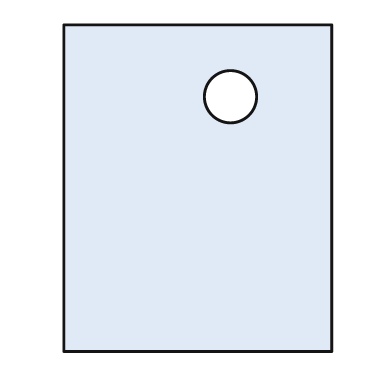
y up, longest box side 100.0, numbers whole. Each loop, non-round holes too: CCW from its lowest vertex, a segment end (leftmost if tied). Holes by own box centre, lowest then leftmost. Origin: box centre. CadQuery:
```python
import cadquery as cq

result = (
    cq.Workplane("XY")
    .moveTo(-41.0, -50.0)
    .lineTo(41.0, -50.0)
    .lineTo(41.0, 50.0)
    .lineTo(-41.0, 50.0)
    .close()
    .moveTo(10.0, 28.0)
    .circle(8.0)
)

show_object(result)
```